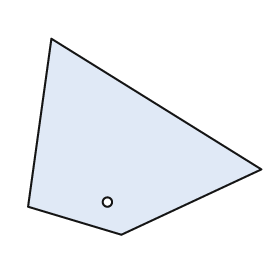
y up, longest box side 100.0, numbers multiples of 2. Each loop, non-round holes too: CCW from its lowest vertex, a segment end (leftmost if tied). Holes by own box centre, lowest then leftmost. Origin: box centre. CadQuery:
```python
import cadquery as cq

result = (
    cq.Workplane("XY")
    .moveTo(-10.0, -42.0)
    .lineTo(50.0, -14.0)
    .lineTo(-40.0, 42.0)
    .lineTo(-50.0, -30.0)
    .close()
    .moveTo(-16.0, -28.0)
    .circle(2.0)
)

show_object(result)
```